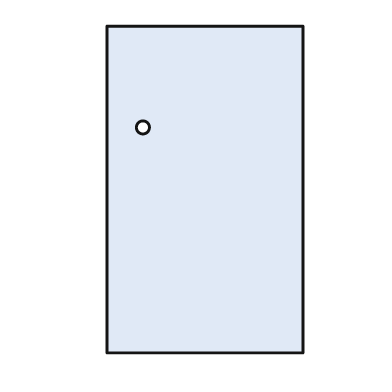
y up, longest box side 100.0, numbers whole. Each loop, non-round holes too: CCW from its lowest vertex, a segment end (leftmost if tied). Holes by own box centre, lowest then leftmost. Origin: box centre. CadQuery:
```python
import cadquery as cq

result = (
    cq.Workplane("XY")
    .moveTo(-30.0, -50.0)
    .lineTo(30.0, -50.0)
    .lineTo(30.0, 50.0)
    .lineTo(-30.0, 50.0)
    .close()
    .moveTo(-19.0, 19.0)
    .circle(2.0)
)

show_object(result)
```